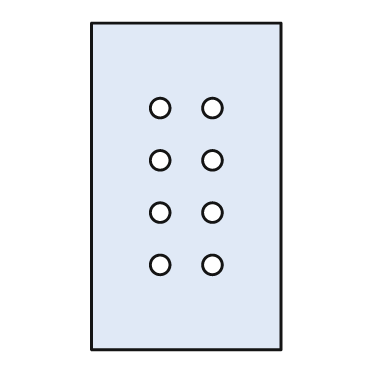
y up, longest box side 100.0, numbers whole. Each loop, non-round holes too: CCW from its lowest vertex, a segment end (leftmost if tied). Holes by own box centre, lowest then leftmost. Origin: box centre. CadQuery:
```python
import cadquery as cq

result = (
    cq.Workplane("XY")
    .moveTo(-29.0, -50.0)
    .lineTo(29.0, -50.0)
    .lineTo(29.0, 50.0)
    .lineTo(-29.0, 50.0)
    .close()
    .moveTo(-8.0, -24.0)
    .circle(3.0)
    .moveTo(8.0, -24.0)
    .circle(3.0)
    .moveTo(-8.0, -8.0)
    .circle(3.0)
    .moveTo(8.0, -8.0)
    .circle(3.0)
    .moveTo(-8.0, 8.0)
    .circle(3.0)
    .moveTo(8.0, 8.0)
    .circle(3.0)
    .moveTo(-8.0, 24.0)
    .circle(3.0)
    .moveTo(8.0, 24.0)
    .circle(3.0)
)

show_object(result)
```